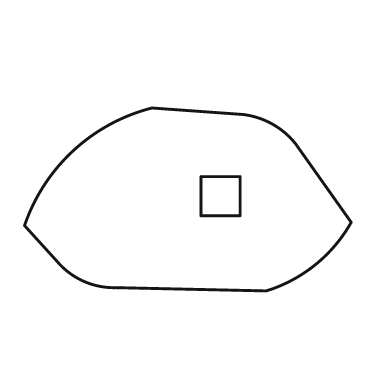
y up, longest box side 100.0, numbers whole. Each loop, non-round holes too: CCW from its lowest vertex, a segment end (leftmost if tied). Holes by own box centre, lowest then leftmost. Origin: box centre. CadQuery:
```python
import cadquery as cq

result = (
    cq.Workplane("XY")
    .moveTo(24.0, -28.0)
    .threePointArc((39.0, -20.0), (50.0, -7.0))
    .lineTo(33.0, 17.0)
    .threePointArc((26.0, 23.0), (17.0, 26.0))
    .lineTo(-11.0, 28.0)
    .threePointArc((-35.0, 15.0), (-50.0, -8.0))
    .lineTo(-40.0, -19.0)
    .threePointArc((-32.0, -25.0), (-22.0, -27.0))
    .close()
    .moveTo(4.0, -5.0)
    .lineTo(16.0, -5.0)
    .lineTo(16.0, 7.0)
    .lineTo(4.0, 7.0)
    .close()
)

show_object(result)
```